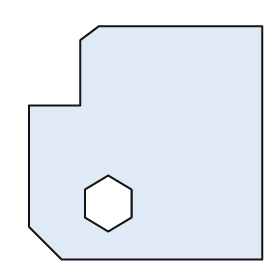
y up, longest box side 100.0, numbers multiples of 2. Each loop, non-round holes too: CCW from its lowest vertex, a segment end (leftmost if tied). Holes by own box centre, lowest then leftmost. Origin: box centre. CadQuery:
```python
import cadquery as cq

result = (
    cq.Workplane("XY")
    .moveTo(-36.0, -50.0)
    .lineTo(50.0, -50.0)
    .lineTo(50.0, 50.0)
    .lineTo(-20.0, 50.0)
    .lineTo(-28.0, 44.0)
    .lineTo(-28.0, 16.0)
    .lineTo(-50.0, 16.0)
    .lineTo(-50.0, -36.0)
    .close()
    .moveTo(-16.0, -38.0)
    .lineTo(-6.0, -32.0)
    .lineTo(-6.0, -20.0)
    .lineTo(-16.0, -14.0)
    .lineTo(-26.0, -20.0)
    .lineTo(-26.0, -32.0)
    .close()
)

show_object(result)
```